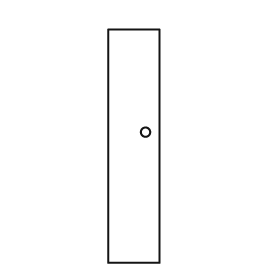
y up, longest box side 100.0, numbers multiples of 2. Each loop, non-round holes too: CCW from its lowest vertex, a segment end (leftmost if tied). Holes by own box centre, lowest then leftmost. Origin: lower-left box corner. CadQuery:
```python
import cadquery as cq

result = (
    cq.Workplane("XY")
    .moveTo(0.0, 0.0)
    .lineTo(22.0, 0.0)
    .lineTo(22.0, 100.0)
    .lineTo(0.0, 100.0)
    .close()
    .moveTo(16.0, 56.0)
    .circle(2.0)
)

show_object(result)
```